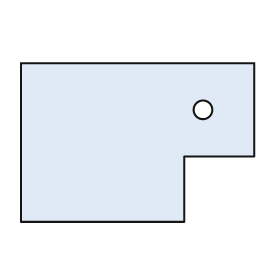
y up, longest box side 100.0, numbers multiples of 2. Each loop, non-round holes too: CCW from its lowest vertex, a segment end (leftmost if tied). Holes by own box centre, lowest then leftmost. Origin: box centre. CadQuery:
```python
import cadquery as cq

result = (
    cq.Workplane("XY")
    .moveTo(-50.0, -34.0)
    .lineTo(20.0, -34.0)
    .lineTo(20.0, -6.0)
    .lineTo(50.0, -6.0)
    .lineTo(50.0, 34.0)
    .lineTo(-50.0, 34.0)
    .close()
    .moveTo(28.0, 14.0)
    .circle(4.0)
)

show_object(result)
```